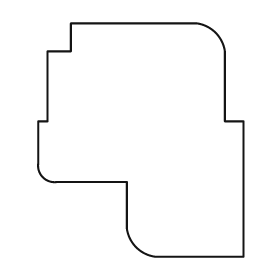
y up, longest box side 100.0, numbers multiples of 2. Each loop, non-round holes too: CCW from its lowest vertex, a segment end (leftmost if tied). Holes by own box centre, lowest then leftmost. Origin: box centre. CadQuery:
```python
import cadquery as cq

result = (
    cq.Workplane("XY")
    .moveTo(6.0, -50.0)
    .lineTo(44.0, -50.0)
    .lineTo(44.0, 8.0)
    .lineTo(36.0, 8.0)
    .lineTo(36.0, 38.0)
    .threePointArc((32.0, 46.0), (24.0, 50.0))
    .lineTo(-30.0, 50.0)
    .lineTo(-30.0, 38.0)
    .lineTo(-40.0, 38.0)
    .lineTo(-40.0, 8.0)
    .lineTo(-44.0, 8.0)
    .lineTo(-44.0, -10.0)
    .threePointArc((-42.0, -16.0), (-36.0, -18.0))
    .lineTo(-6.0, -18.0)
    .lineTo(-6.0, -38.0)
    .threePointArc((-2.0, -46.0), (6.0, -50.0))
    .close()
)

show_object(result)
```